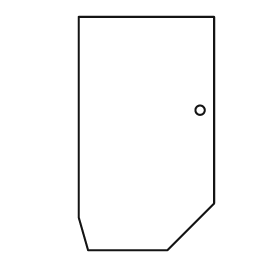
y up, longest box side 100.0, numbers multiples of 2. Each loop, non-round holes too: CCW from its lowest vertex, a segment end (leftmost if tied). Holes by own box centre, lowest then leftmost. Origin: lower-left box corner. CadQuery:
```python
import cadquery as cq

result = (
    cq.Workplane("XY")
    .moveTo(4.0, 0.0)
    .lineTo(38.0, 0.0)
    .lineTo(58.0, 20.0)
    .lineTo(58.0, 100.0)
    .lineTo(0.0, 100.0)
    .lineTo(0.0, 14.0)
    .close()
    .moveTo(52.0, 60.0)
    .circle(2.0)
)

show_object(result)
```